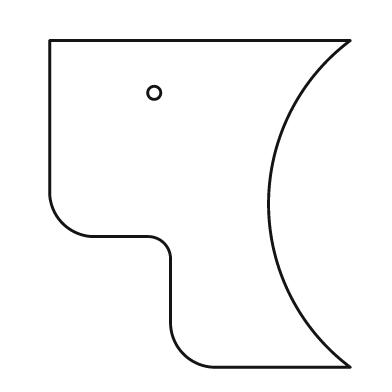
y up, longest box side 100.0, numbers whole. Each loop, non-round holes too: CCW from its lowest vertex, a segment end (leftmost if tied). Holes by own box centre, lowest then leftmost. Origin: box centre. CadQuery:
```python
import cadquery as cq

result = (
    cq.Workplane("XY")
    .moveTo(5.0, -50.0)
    .lineTo(46.0, -50.0)
    .threePointArc((21.0, 0.0), (46.0, 50.0))
    .lineTo(-46.0, 50.0)
    .lineTo(-46.0, 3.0)
    .threePointArc((-42.0, -6.0), (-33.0, -10.0))
    .lineTo(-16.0, -10.0)
    .threePointArc((-11.0, -12.0), (-9.0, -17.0))
    .lineTo(-9.0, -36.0)
    .threePointArc((-5.0, -46.0), (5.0, -50.0))
    .close()
    .moveTo(-14.0, 34.0)
    .circle(2.0)
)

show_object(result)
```